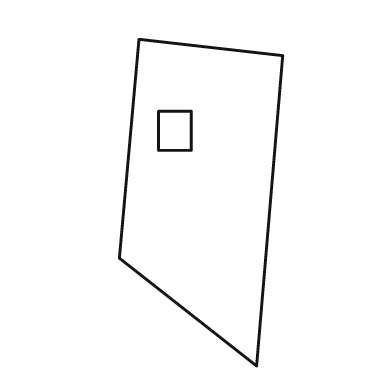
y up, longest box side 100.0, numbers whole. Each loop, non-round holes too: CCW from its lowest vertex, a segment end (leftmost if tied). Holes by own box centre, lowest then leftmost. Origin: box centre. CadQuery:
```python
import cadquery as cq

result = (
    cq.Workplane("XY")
    .moveTo(17.0, -50.0)
    .lineTo(25.0, 45.0)
    .lineTo(-19.0, 50.0)
    .lineTo(-25.0, -17.0)
    .close()
    .moveTo(-13.0, 16.0)
    .lineTo(-3.0, 16.0)
    .lineTo(-3.0, 28.0)
    .lineTo(-13.0, 28.0)
    .close()
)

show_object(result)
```